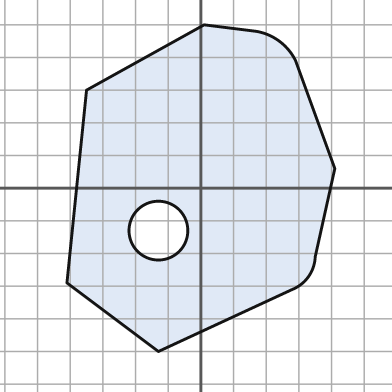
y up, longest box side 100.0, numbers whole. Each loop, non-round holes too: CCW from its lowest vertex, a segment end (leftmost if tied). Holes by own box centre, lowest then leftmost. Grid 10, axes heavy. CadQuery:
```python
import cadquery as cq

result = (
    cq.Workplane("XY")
    .moveTo(-13.0, -50.0)
    .lineTo(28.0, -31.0)
    .threePointArc((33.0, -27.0), (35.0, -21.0))
    .lineTo(41.0, 6.0)
    .lineTo(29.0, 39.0)
    .threePointArc((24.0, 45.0), (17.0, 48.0))
    .lineTo(1.0, 50.0)
    .lineTo(-35.0, 30.0)
    .lineTo(-41.0, -29.0)
    .close()
    .moveTo(-13.0, -13.0)
    .circle(9.0)
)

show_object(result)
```